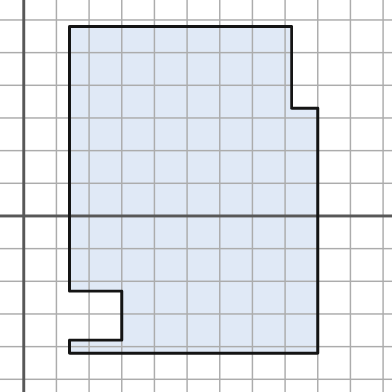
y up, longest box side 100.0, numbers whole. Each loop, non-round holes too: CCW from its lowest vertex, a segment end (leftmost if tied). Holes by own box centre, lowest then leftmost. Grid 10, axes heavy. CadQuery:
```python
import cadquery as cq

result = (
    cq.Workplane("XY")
    .moveTo(14.0, -42.0)
    .lineTo(90.0, -42.0)
    .lineTo(90.0, 33.0)
    .lineTo(82.0, 33.0)
    .lineTo(82.0, 58.0)
    .lineTo(14.0, 58.0)
    .lineTo(14.0, -23.0)
    .lineTo(30.0, -23.0)
    .lineTo(30.0, -38.0)
    .lineTo(14.0, -38.0)
    .close()
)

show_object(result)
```